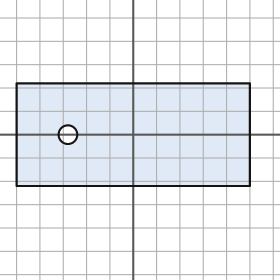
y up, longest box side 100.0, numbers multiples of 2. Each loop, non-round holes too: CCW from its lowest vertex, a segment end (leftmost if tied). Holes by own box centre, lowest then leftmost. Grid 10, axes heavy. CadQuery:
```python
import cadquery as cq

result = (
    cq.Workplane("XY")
    .moveTo(-50.0, -22.0)
    .lineTo(50.0, -22.0)
    .lineTo(50.0, 22.0)
    .lineTo(-50.0, 22.0)
    .close()
    .moveTo(-28.0, 0.0)
    .circle(4.0)
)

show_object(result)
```